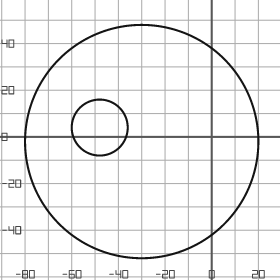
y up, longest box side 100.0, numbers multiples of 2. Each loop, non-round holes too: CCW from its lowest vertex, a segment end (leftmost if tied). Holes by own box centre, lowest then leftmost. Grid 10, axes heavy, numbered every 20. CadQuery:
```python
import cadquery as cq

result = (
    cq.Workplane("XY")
    .moveTo(-30.0, -2.0)
    .circle(50.0)
    .moveTo(-48.0, 4.0)
    .circle(12.0)
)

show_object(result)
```